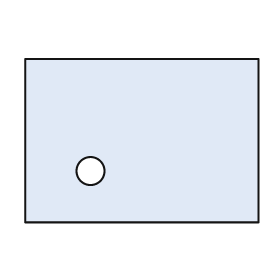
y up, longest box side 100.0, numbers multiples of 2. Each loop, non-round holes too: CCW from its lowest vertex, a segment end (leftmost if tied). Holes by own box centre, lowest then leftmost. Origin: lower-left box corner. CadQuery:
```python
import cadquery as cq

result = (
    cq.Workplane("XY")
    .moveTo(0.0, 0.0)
    .lineTo(100.0, 0.0)
    .lineTo(100.0, 70.0)
    .lineTo(0.0, 70.0)
    .close()
    .moveTo(28.0, 22.0)
    .circle(6.0)
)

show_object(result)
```